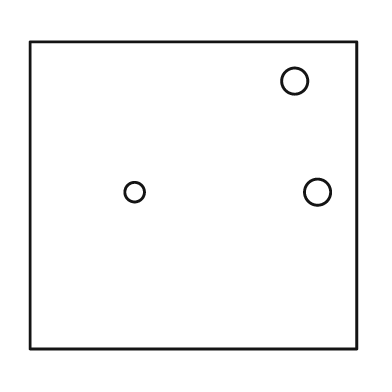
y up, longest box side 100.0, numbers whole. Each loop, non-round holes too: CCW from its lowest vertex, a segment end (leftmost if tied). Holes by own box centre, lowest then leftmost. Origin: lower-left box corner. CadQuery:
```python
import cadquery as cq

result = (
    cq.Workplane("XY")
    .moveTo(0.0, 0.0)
    .lineTo(100.0, 0.0)
    .lineTo(100.0, 94.0)
    .lineTo(0.0, 94.0)
    .close()
    .moveTo(32.0, 48.0)
    .circle(3.0)
    .moveTo(88.0, 48.0)
    .circle(4.0)
    .moveTo(81.0, 82.0)
    .circle(4.0)
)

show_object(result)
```